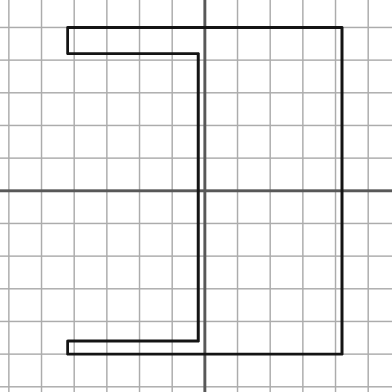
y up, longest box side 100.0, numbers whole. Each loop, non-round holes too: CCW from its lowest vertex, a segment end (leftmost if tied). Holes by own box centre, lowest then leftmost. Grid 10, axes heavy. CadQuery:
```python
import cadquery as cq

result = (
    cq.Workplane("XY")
    .moveTo(-42.0, -50.0)
    .lineTo(42.0, -50.0)
    .lineTo(42.0, 50.0)
    .lineTo(-42.0, 50.0)
    .lineTo(-42.0, 42.0)
    .lineTo(-2.0, 42.0)
    .lineTo(-2.0, -46.0)
    .lineTo(-42.0, -46.0)
    .close()
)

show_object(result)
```